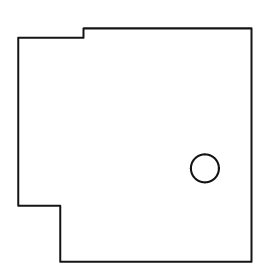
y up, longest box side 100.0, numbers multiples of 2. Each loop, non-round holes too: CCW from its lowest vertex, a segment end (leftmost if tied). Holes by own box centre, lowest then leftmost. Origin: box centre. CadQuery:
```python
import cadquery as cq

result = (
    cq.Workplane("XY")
    .moveTo(-32.0, -50.0)
    .lineTo(50.0, -50.0)
    .lineTo(50.0, 50.0)
    .lineTo(-22.0, 50.0)
    .lineTo(-22.0, 46.0)
    .lineTo(-50.0, 46.0)
    .lineTo(-50.0, -26.0)
    .lineTo(-32.0, -26.0)
    .close()
    .moveTo(30.0, -10.0)
    .circle(6.0)
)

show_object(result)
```